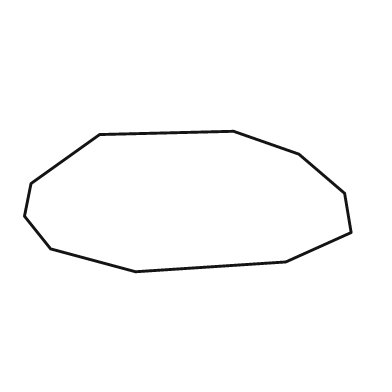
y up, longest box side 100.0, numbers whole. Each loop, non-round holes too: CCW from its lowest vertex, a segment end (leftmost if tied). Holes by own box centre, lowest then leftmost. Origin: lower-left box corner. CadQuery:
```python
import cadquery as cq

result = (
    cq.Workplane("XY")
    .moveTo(34.0, 0.0)
    .lineTo(80.0, 3.0)
    .lineTo(100.0, 12.0)
    .lineTo(98.0, 24.0)
    .lineTo(84.0, 36.0)
    .lineTo(64.0, 43.0)
    .lineTo(23.0, 42.0)
    .lineTo(2.0, 27.0)
    .lineTo(0.0, 17.0)
    .lineTo(8.0, 7.0)
    .close()
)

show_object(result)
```